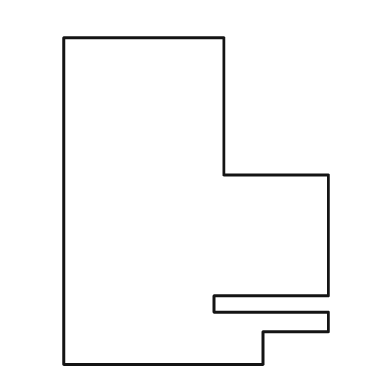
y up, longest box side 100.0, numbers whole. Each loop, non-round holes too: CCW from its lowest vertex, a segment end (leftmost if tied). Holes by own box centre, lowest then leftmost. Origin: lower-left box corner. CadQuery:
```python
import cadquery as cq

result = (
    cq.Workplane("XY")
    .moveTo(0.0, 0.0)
    .lineTo(61.0, 0.0)
    .lineTo(61.0, 10.0)
    .lineTo(81.0, 10.0)
    .lineTo(81.0, 16.0)
    .lineTo(46.0, 16.0)
    .lineTo(46.0, 21.0)
    .lineTo(81.0, 21.0)
    .lineTo(81.0, 58.0)
    .lineTo(49.0, 58.0)
    .lineTo(49.0, 100.0)
    .lineTo(0.0, 100.0)
    .close()
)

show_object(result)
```